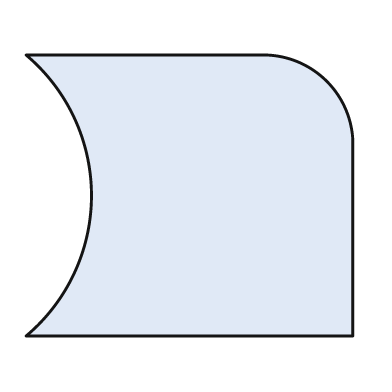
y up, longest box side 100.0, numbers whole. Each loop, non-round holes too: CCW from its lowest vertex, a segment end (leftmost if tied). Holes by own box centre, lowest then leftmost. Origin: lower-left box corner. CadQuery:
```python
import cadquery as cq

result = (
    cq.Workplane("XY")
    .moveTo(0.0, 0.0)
    .lineTo(100.0, 0.0)
    .lineTo(100.0, 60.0)
    .threePointArc((92.0, 78.0), (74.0, 86.0))
    .lineTo(0.0, 86.0)
    .threePointArc((20.0, 43.0), (0.0, 0.0))
    .close()
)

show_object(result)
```